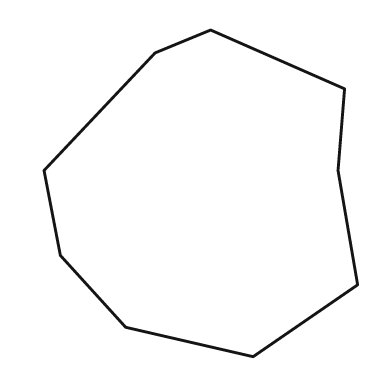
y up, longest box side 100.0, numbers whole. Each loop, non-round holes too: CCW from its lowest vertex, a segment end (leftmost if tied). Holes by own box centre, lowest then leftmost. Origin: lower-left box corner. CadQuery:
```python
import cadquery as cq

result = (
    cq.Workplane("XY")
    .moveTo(64.0, 0.0)
    .lineTo(96.0, 22.0)
    .lineTo(90.0, 57.0)
    .lineTo(92.0, 82.0)
    .lineTo(51.0, 100.0)
    .lineTo(34.0, 93.0)
    .lineTo(0.0, 57.0)
    .lineTo(5.0, 31.0)
    .lineTo(25.0, 9.0)
    .close()
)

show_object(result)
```